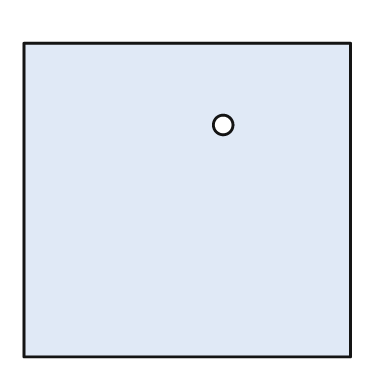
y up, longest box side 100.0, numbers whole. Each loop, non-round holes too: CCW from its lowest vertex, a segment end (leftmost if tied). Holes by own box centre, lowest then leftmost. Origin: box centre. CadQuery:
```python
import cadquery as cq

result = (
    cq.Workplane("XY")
    .moveTo(-50.0, -48.0)
    .lineTo(50.0, -48.0)
    .lineTo(50.0, 48.0)
    .lineTo(-50.0, 48.0)
    .close()
    .moveTo(11.0, 23.0)
    .circle(3.0)
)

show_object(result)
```